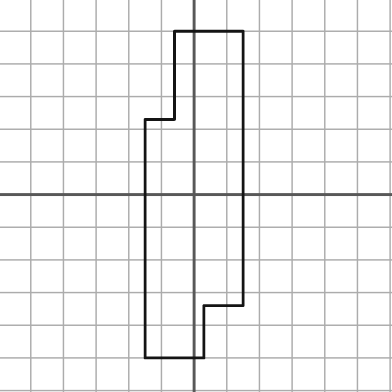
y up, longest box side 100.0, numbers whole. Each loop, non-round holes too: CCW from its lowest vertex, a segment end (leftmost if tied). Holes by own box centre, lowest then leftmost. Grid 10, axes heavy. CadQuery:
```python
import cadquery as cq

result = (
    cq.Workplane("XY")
    .moveTo(-15.0, -50.0)
    .lineTo(3.0, -50.0)
    .lineTo(3.0, -34.0)
    .lineTo(15.0, -34.0)
    .lineTo(15.0, 50.0)
    .lineTo(-6.0, 50.0)
    .lineTo(-6.0, 23.0)
    .lineTo(-15.0, 23.0)
    .close()
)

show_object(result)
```